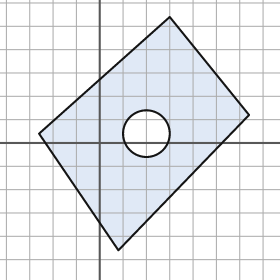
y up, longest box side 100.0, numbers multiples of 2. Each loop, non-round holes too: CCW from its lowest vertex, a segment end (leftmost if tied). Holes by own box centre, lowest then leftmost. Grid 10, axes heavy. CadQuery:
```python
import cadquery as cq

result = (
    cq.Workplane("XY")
    .moveTo(8.0, -46.0)
    .lineTo(64.0, 12.0)
    .lineTo(30.0, 54.0)
    .lineTo(-26.0, 4.0)
    .close()
    .moveTo(20.0, 4.0)
    .circle(10.0)
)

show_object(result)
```